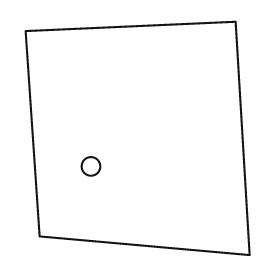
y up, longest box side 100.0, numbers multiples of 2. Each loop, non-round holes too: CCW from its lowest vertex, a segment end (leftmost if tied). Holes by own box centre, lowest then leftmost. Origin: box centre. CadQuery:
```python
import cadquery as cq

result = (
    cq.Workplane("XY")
    .moveTo(48.0, -50.0)
    .lineTo(42.0, 50.0)
    .lineTo(-48.0, 46.0)
    .lineTo(-42.0, -42.0)
    .close()
    .moveTo(-20.0, -12.0)
    .circle(4.0)
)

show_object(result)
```